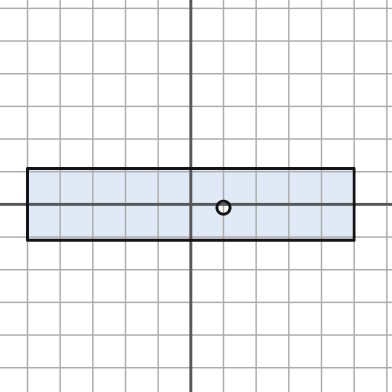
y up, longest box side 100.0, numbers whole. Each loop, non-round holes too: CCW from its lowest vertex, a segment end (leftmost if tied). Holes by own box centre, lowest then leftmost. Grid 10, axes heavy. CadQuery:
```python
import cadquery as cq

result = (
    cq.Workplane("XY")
    .moveTo(-50.0, -11.0)
    .lineTo(50.0, -11.0)
    .lineTo(50.0, 11.0)
    .lineTo(-50.0, 11.0)
    .close()
    .moveTo(10.0, -1.0)
    .circle(2.0)
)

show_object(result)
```